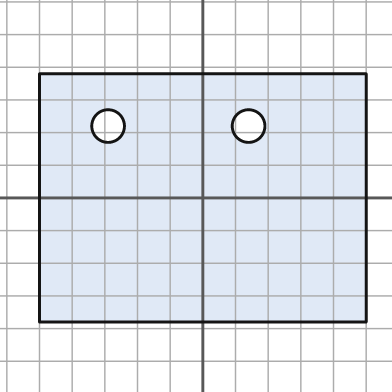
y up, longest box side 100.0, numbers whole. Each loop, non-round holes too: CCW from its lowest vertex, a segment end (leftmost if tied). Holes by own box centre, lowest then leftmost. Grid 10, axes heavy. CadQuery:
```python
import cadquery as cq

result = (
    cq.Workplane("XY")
    .moveTo(-50.0, -38.0)
    .lineTo(50.0, -38.0)
    .lineTo(50.0, 38.0)
    .lineTo(-50.0, 38.0)
    .close()
    .moveTo(-29.0, 22.0)
    .circle(5.0)
    .moveTo(14.0, 22.0)
    .circle(5.0)
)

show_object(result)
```